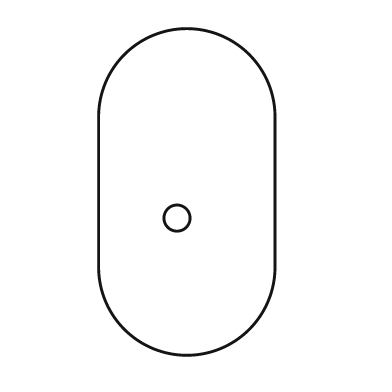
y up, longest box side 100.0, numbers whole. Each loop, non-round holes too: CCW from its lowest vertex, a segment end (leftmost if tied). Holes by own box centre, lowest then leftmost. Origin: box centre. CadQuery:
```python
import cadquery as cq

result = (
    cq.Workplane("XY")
    .moveTo(-27.0, -23.0)
    .threePointArc((0.0, -50.0), (27.0, -23.0))
    .lineTo(27.0, 23.0)
    .threePointArc((0.0, 50.0), (-27.0, 23.0))
    .close()
    .moveTo(-3.0, -8.0)
    .circle(4.0)
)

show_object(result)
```